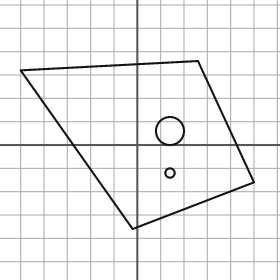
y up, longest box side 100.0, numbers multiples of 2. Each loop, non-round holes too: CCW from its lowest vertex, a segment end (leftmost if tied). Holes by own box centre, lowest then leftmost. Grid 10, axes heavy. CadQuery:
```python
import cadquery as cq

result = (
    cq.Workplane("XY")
    .moveTo(-2.0, -36.0)
    .lineTo(50.0, -16.0)
    .lineTo(26.0, 36.0)
    .lineTo(-50.0, 32.0)
    .close()
    .moveTo(14.0, -12.0)
    .circle(2.0)
    .moveTo(14.0, 6.0)
    .circle(6.0)
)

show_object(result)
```